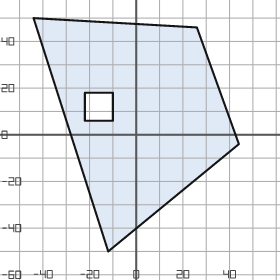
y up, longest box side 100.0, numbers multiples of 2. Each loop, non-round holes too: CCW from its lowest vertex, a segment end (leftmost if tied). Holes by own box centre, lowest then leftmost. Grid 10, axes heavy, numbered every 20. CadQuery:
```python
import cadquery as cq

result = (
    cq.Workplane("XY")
    .moveTo(-12.0, -50.0)
    .lineTo(44.0, -4.0)
    .lineTo(26.0, 46.0)
    .lineTo(-44.0, 50.0)
    .close()
    .moveTo(-22.0, 6.0)
    .lineTo(-10.0, 6.0)
    .lineTo(-10.0, 18.0)
    .lineTo(-22.0, 18.0)
    .close()
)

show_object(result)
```